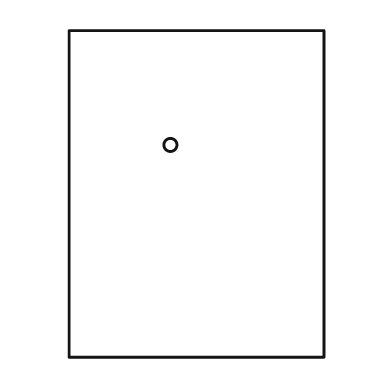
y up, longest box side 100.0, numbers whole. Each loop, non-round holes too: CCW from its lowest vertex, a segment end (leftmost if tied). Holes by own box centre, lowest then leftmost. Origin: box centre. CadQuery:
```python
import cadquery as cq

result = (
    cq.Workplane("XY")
    .moveTo(-39.0, -50.0)
    .lineTo(39.0, -50.0)
    .lineTo(39.0, 50.0)
    .lineTo(-39.0, 50.0)
    .close()
    .moveTo(-8.0, 15.0)
    .circle(2.0)
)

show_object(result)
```